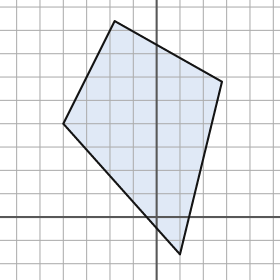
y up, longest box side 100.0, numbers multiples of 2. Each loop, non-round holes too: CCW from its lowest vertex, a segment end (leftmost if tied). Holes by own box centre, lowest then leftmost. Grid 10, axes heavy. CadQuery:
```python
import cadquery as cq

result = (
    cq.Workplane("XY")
    .moveTo(10.0, -16.0)
    .lineTo(28.0, 58.0)
    .lineTo(-18.0, 84.0)
    .lineTo(-40.0, 40.0)
    .close()
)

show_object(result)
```